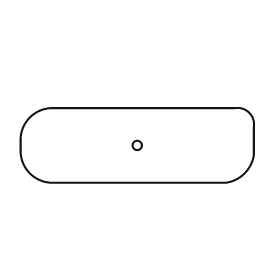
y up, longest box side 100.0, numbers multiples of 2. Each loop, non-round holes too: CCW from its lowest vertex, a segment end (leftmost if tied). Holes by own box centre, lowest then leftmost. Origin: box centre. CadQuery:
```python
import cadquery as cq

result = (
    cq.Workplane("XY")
    .moveTo(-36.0, -16.0)
    .lineTo(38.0, -16.0)
    .threePointArc((46.0, -12.0), (50.0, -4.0))
    .lineTo(50.0, 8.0)
    .threePointArc((48.0, 14.0), (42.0, 16.0))
    .lineTo(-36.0, 16.0)
    .threePointArc((-46.0, 12.0), (-50.0, 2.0))
    .lineTo(-50.0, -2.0)
    .threePointArc((-46.0, -12.0), (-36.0, -16.0))
    .close()
    .moveTo(0.0, 0.0)
    .circle(2.0)
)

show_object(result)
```